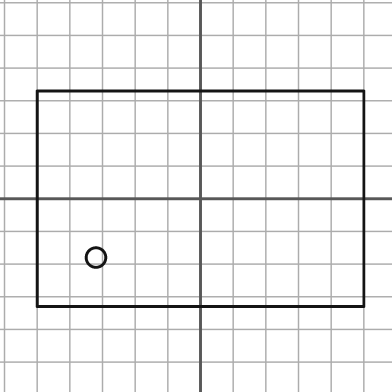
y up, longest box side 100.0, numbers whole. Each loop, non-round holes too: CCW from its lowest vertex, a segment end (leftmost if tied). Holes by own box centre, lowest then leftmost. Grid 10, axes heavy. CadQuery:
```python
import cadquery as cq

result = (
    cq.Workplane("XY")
    .moveTo(-50.0, -33.0)
    .lineTo(50.0, -33.0)
    .lineTo(50.0, 33.0)
    .lineTo(-50.0, 33.0)
    .close()
    .moveTo(-32.0, -18.0)
    .circle(3.0)
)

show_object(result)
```